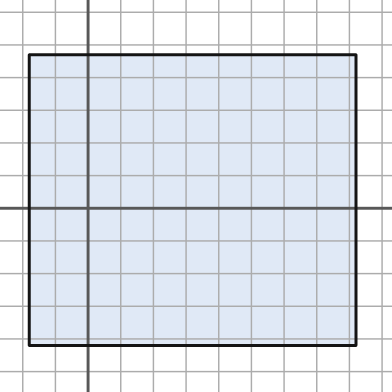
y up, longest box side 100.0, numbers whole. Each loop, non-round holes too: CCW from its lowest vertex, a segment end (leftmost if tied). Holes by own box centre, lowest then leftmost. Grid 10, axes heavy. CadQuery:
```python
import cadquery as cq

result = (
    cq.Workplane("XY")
    .moveTo(-18.0, -42.0)
    .lineTo(82.0, -42.0)
    .lineTo(82.0, 47.0)
    .lineTo(-18.0, 47.0)
    .close()
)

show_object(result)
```